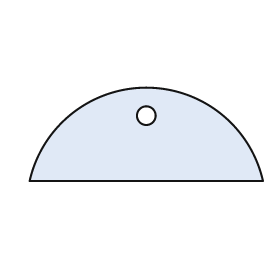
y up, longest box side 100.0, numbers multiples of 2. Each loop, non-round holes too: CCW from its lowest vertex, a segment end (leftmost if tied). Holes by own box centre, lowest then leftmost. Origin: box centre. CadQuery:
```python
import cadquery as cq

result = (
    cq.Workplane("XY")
    .moveTo(-50.0, -20.0)
    .lineTo(50.0, -20.0)
    .threePointArc((0.0, 20.0), (-50.0, -20.0))
    .close()
    .moveTo(0.0, 8.0)
    .circle(4.0)
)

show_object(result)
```